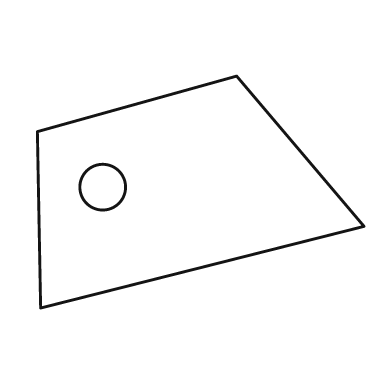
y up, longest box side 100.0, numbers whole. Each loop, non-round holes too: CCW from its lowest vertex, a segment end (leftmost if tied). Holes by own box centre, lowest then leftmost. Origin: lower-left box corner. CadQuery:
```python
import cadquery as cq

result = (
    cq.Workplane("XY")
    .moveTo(1.0, 0.0)
    .lineTo(100.0, 25.0)
    .lineTo(61.0, 71.0)
    .lineTo(0.0, 54.0)
    .close()
    .moveTo(20.0, 37.0)
    .circle(7.0)
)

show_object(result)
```